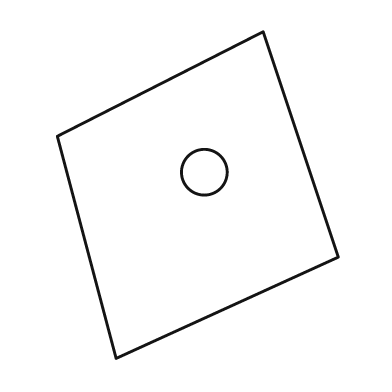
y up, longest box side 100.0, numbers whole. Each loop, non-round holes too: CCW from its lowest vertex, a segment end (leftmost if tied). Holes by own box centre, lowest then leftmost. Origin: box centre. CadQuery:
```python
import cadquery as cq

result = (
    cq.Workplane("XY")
    .moveTo(-25.0, -50.0)
    .lineTo(43.0, -19.0)
    .lineTo(20.0, 50.0)
    .lineTo(-43.0, 18.0)
    .close()
    .moveTo(2.0, 7.0)
    .circle(7.0)
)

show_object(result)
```